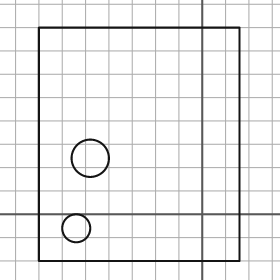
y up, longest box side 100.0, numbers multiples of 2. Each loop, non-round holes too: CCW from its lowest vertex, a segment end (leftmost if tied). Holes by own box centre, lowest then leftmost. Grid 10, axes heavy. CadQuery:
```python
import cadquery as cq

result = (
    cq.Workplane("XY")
    .moveTo(-70.0, -20.0)
    .lineTo(16.0, -20.0)
    .lineTo(16.0, 80.0)
    .lineTo(-70.0, 80.0)
    .close()
    .moveTo(-54.0, -6.0)
    .circle(6.0)
    .moveTo(-48.0, 24.0)
    .circle(8.0)
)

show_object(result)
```